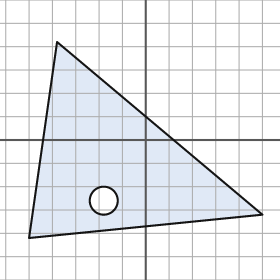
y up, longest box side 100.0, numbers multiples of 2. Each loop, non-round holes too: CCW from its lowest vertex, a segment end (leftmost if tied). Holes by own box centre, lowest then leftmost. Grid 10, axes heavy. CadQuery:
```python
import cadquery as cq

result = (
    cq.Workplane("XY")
    .moveTo(-50.0, -42.0)
    .lineTo(50.0, -32.0)
    .lineTo(-38.0, 42.0)
    .close()
    .moveTo(-18.0, -26.0)
    .circle(6.0)
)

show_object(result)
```